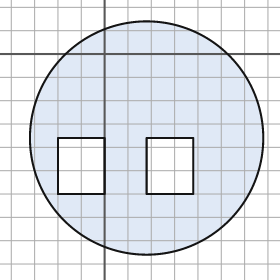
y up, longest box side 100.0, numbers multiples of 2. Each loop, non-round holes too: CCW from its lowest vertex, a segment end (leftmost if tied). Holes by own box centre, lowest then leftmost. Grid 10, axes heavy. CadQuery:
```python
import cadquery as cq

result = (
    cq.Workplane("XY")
    .moveTo(18.0, -36.0)
    .circle(50.0)
    .moveTo(-20.0, -60.0)
    .lineTo(0.0, -60.0)
    .lineTo(0.0, -36.0)
    .lineTo(-20.0, -36.0)
    .close()
    .moveTo(18.0, -60.0)
    .lineTo(38.0, -60.0)
    .lineTo(38.0, -36.0)
    .lineTo(18.0, -36.0)
    .close()
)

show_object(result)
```